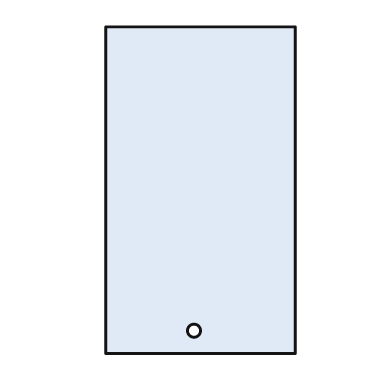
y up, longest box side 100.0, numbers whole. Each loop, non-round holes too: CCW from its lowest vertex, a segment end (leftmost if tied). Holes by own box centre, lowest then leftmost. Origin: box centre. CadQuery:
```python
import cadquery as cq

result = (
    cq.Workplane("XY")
    .moveTo(-29.0, -50.0)
    .lineTo(29.0, -50.0)
    .lineTo(29.0, 50.0)
    .lineTo(-29.0, 50.0)
    .close()
    .moveTo(-2.0, -43.0)
    .circle(2.0)
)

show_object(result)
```